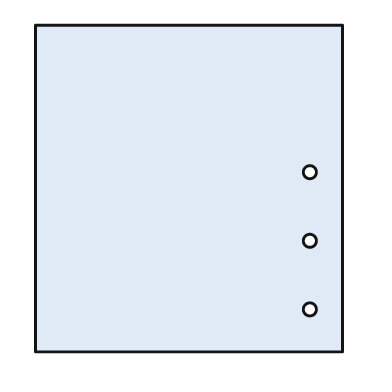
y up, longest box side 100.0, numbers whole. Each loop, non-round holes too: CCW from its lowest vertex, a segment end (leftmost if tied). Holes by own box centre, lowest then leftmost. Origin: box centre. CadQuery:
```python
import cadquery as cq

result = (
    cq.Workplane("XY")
    .moveTo(-47.0, -50.0)
    .lineTo(47.0, -50.0)
    .lineTo(47.0, 50.0)
    .lineTo(-47.0, 50.0)
    .close()
    .moveTo(37.0, -37.0)
    .circle(2.0)
    .moveTo(37.0, -16.0)
    .circle(2.0)
    .moveTo(37.0, 5.0)
    .circle(2.0)
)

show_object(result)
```